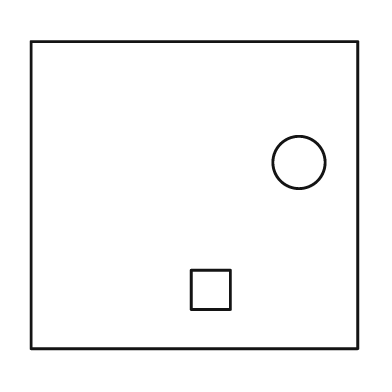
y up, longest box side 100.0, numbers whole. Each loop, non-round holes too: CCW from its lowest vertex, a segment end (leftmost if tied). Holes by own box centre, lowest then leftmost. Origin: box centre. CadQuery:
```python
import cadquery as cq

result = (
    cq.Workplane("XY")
    .moveTo(-50.0, -47.0)
    .lineTo(50.0, -47.0)
    .lineTo(50.0, 47.0)
    .lineTo(-50.0, 47.0)
    .close()
    .moveTo(-1.0, -35.0)
    .lineTo(11.0, -35.0)
    .lineTo(11.0, -23.0)
    .lineTo(-1.0, -23.0)
    .close()
    .moveTo(32.0, 10.0)
    .circle(8.0)
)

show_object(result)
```